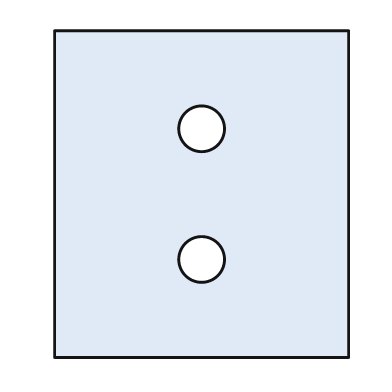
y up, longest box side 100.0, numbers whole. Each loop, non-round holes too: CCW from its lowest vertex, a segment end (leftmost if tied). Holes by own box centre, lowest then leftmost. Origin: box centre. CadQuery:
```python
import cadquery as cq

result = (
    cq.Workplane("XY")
    .moveTo(-45.0, -50.0)
    .lineTo(45.0, -50.0)
    .lineTo(45.0, 50.0)
    .lineTo(-45.0, 50.0)
    .close()
    .moveTo(0.0, -20.0)
    .circle(7.0)
    .moveTo(0.0, 20.0)
    .circle(7.0)
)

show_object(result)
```